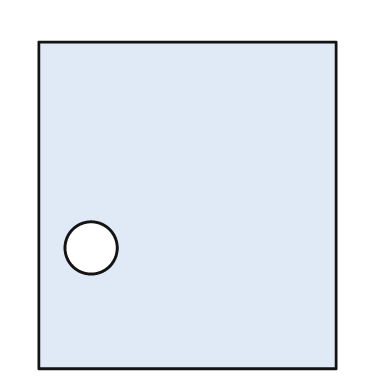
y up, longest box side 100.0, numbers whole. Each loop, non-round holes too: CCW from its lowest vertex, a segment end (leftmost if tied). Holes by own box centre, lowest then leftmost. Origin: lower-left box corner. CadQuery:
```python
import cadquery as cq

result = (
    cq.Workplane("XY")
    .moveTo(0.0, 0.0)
    .lineTo(91.0, 0.0)
    .lineTo(91.0, 100.0)
    .lineTo(0.0, 100.0)
    .close()
    .moveTo(16.0, 37.0)
    .circle(8.0)
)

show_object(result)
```